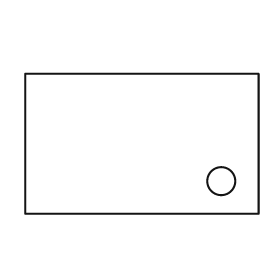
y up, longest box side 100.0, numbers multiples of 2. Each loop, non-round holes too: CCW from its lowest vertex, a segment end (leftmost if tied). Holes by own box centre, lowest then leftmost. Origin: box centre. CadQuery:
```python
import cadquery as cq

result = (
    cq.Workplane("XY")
    .moveTo(-50.0, -30.0)
    .lineTo(50.0, -30.0)
    .lineTo(50.0, 30.0)
    .lineTo(-50.0, 30.0)
    .close()
    .moveTo(34.0, -16.0)
    .circle(6.0)
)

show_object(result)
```